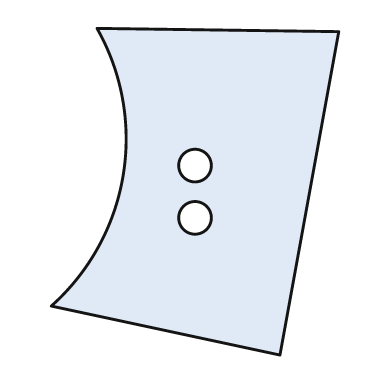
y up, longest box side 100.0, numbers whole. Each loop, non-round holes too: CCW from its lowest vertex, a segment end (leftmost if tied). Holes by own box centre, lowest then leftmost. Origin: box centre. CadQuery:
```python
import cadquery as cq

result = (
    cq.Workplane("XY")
    .moveTo(26.0, -50.0)
    .lineTo(44.0, 49.0)
    .lineTo(-30.0, 50.0)
    .threePointArc((-22.0, 5.0), (-44.0, -35.0))
    .close()
    .moveTo(0.0, -8.0)
    .circle(5.0)
    .moveTo(0.0, 8.0)
    .circle(5.0)
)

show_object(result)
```